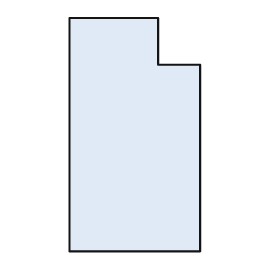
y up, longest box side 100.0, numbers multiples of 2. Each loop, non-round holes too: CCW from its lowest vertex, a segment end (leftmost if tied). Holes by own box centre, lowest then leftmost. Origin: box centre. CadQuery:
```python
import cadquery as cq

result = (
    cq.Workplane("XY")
    .moveTo(-28.0, -50.0)
    .lineTo(28.0, -50.0)
    .lineTo(28.0, 30.0)
    .lineTo(10.0, 30.0)
    .lineTo(10.0, 50.0)
    .lineTo(-28.0, 50.0)
    .close()
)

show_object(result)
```